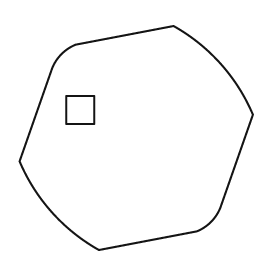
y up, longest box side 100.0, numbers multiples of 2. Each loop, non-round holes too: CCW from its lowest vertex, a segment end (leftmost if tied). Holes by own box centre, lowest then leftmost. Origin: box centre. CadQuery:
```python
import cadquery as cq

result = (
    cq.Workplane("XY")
    .moveTo(-16.0, -48.0)
    .lineTo(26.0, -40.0)
    .threePointArc((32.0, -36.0), (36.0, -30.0))
    .lineTo(50.0, 10.0)
    .threePointArc((36.0, 32.0), (16.0, 48.0))
    .lineTo(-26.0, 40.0)
    .threePointArc((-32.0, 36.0), (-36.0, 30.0))
    .lineTo(-50.0, -10.0)
    .threePointArc((-36.0, -32.0), (-16.0, -48.0))
    .close()
    .moveTo(-30.0, 6.0)
    .lineTo(-18.0, 6.0)
    .lineTo(-18.0, 18.0)
    .lineTo(-30.0, 18.0)
    .close()
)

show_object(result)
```